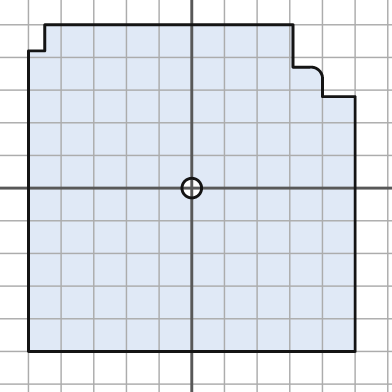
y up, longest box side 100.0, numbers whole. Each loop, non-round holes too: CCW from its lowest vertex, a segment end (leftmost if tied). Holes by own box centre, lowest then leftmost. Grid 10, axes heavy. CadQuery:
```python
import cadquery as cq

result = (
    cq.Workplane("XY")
    .moveTo(-50.0, -50.0)
    .lineTo(50.0, -50.0)
    .lineTo(50.0, 28.0)
    .lineTo(40.0, 28.0)
    .lineTo(40.0, 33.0)
    .threePointArc((39.0, 36.0), (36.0, 37.0))
    .lineTo(31.0, 37.0)
    .lineTo(31.0, 50.0)
    .lineTo(-45.0, 50.0)
    .lineTo(-45.0, 42.0)
    .lineTo(-50.0, 42.0)
    .close()
    .moveTo(0.0, 0.0)
    .circle(3.0)
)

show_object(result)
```